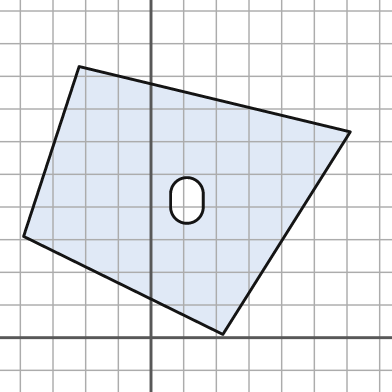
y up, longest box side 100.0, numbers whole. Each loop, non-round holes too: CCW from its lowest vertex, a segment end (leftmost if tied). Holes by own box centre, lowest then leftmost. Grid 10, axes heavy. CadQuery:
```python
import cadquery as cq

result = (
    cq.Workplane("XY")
    .moveTo(22.0, 1.0)
    .lineTo(61.0, 63.0)
    .lineTo(-22.0, 83.0)
    .lineTo(-39.0, 31.0)
    .close()
    .moveTo(6.0, 40.0)
    .threePointArc((11.0, 35.0), (16.0, 40.0))
    .lineTo(16.0, 44.0)
    .threePointArc((11.0, 49.0), (6.0, 44.0))
    .close()
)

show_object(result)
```